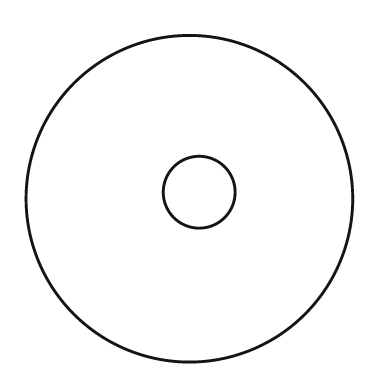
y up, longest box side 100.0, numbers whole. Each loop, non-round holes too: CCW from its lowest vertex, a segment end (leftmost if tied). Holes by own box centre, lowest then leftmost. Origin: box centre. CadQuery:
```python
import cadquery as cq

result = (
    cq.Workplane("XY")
    .moveTo(0.0, 0.0)
    .circle(50.0)
    .moveTo(3.0, 2.0)
    .circle(11.0)
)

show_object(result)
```